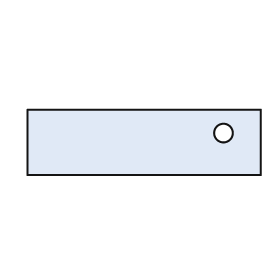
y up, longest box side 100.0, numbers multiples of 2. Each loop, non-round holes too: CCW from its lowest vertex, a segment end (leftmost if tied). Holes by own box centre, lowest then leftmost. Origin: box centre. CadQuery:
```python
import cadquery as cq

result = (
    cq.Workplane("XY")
    .moveTo(-50.0, -14.0)
    .lineTo(50.0, -14.0)
    .lineTo(50.0, 14.0)
    .lineTo(-50.0, 14.0)
    .close()
    .moveTo(34.0, 4.0)
    .circle(4.0)
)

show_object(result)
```